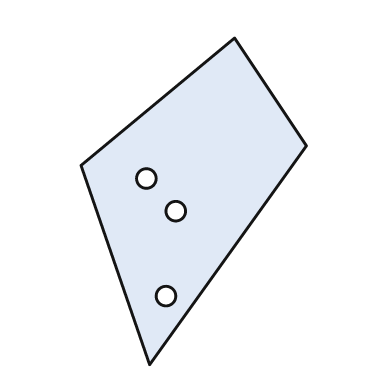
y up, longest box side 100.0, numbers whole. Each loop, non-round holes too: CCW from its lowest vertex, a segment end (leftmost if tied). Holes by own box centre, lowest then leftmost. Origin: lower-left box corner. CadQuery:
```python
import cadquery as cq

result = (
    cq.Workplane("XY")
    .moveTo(21.0, 0.0)
    .lineTo(69.0, 67.0)
    .lineTo(47.0, 100.0)
    .lineTo(0.0, 61.0)
    .close()
    .moveTo(26.0, 21.0)
    .circle(3.0)
    .moveTo(29.0, 47.0)
    .circle(3.0)
    .moveTo(20.0, 57.0)
    .circle(3.0)
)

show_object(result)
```